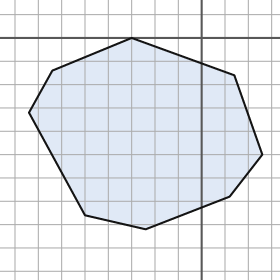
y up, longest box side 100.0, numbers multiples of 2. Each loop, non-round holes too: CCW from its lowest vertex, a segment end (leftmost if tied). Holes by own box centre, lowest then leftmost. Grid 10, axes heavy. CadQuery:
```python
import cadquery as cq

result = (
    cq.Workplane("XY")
    .moveTo(-24.0, -82.0)
    .lineTo(12.0, -68.0)
    .lineTo(26.0, -50.0)
    .lineTo(14.0, -16.0)
    .lineTo(-30.0, 0.0)
    .lineTo(-64.0, -14.0)
    .lineTo(-74.0, -32.0)
    .lineTo(-50.0, -76.0)
    .close()
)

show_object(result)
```